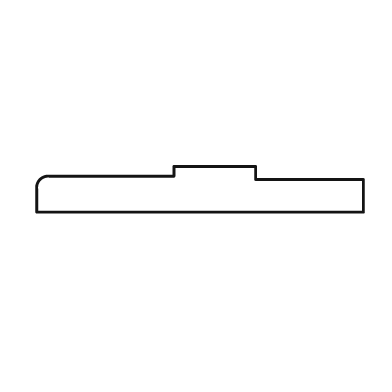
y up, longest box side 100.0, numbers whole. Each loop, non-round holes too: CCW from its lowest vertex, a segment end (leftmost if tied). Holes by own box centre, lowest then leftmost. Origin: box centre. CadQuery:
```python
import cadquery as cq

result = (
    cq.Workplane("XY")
    .moveTo(-50.0, -7.0)
    .lineTo(50.0, -7.0)
    .lineTo(50.0, 3.0)
    .lineTo(17.0, 3.0)
    .lineTo(17.0, 7.0)
    .lineTo(-8.0, 7.0)
    .lineTo(-8.0, 4.0)
    .lineTo(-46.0, 4.0)
    .threePointArc((-49.0, 3.0), (-50.0, 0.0))
    .close()
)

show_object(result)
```